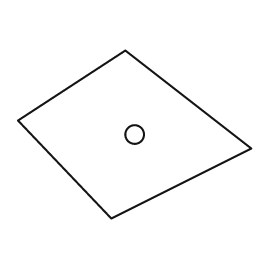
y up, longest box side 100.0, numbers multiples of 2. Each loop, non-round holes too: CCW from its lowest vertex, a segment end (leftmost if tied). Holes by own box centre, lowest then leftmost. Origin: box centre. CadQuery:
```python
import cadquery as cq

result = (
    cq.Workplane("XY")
    .moveTo(-10.0, -36.0)
    .lineTo(50.0, -6.0)
    .lineTo(-4.0, 36.0)
    .lineTo(-50.0, 6.0)
    .close()
    .moveTo(0.0, 0.0)
    .circle(4.0)
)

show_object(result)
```